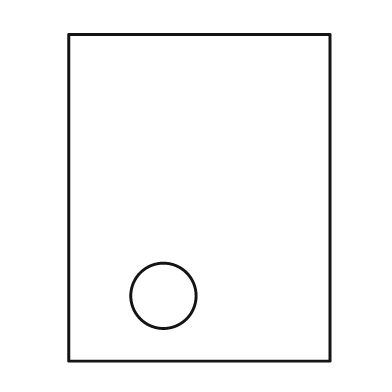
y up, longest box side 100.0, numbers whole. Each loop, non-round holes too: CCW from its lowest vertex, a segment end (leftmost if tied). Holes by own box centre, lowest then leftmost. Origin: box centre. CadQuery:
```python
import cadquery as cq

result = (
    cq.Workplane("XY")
    .moveTo(-40.0, -50.0)
    .lineTo(40.0, -50.0)
    .lineTo(40.0, 50.0)
    .lineTo(-40.0, 50.0)
    .close()
    .moveTo(-11.0, -30.0)
    .circle(10.0)
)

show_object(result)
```